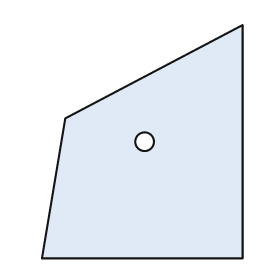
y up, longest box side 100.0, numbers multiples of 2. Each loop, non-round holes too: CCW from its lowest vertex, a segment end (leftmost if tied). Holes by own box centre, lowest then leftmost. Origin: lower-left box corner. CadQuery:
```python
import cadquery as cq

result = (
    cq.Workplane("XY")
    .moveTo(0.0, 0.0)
    .lineTo(86.0, 0.0)
    .lineTo(86.0, 100.0)
    .lineTo(10.0, 60.0)
    .close()
    .moveTo(44.0, 50.0)
    .circle(4.0)
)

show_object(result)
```